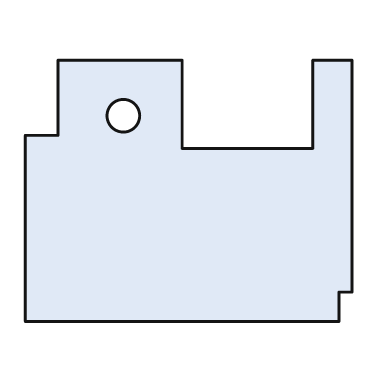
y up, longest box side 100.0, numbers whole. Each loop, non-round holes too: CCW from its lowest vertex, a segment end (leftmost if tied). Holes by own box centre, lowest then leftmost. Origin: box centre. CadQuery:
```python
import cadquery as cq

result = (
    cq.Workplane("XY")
    .moveTo(-50.0, -40.0)
    .lineTo(46.0, -40.0)
    .lineTo(46.0, -31.0)
    .lineTo(50.0, -31.0)
    .lineTo(50.0, 40.0)
    .lineTo(38.0, 40.0)
    .lineTo(38.0, 13.0)
    .lineTo(-2.0, 13.0)
    .lineTo(-2.0, 40.0)
    .lineTo(-40.0, 40.0)
    .lineTo(-40.0, 17.0)
    .lineTo(-50.0, 17.0)
    .close()
    .moveTo(-20.0, 23.0)
    .circle(5.0)
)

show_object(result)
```